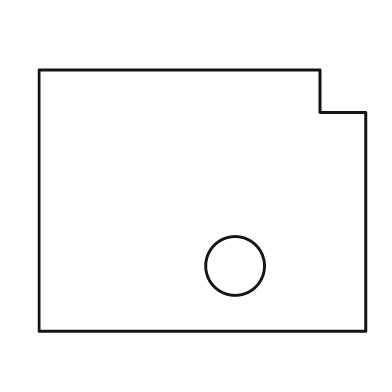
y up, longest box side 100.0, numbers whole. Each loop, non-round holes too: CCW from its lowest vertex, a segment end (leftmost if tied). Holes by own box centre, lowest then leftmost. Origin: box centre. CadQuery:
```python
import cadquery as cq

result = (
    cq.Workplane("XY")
    .moveTo(-50.0, -40.0)
    .lineTo(50.0, -40.0)
    .lineTo(50.0, 27.0)
    .lineTo(36.0, 27.0)
    .lineTo(36.0, 40.0)
    .lineTo(-50.0, 40.0)
    .close()
    .moveTo(10.0, -20.0)
    .circle(9.0)
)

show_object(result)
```